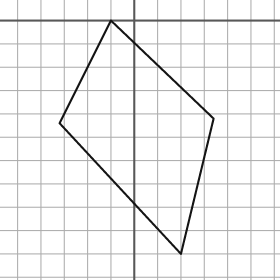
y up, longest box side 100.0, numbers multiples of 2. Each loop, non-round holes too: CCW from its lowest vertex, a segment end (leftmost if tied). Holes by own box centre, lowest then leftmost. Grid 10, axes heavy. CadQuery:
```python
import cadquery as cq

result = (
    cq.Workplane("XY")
    .moveTo(20.0, -100.0)
    .lineTo(34.0, -42.0)
    .lineTo(-10.0, 0.0)
    .lineTo(-32.0, -44.0)
    .close()
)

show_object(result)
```